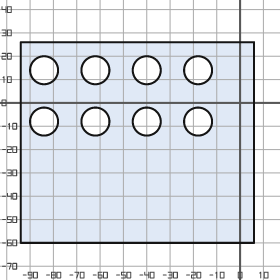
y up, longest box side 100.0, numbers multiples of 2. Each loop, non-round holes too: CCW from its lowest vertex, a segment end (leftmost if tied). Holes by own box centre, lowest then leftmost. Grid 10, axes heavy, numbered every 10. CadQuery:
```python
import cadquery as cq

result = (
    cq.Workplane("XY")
    .moveTo(-94.0, -60.0)
    .lineTo(6.0, -60.0)
    .lineTo(6.0, 26.0)
    .lineTo(-94.0, 26.0)
    .close()
    .moveTo(-84.0, -8.0)
    .circle(6.0)
    .moveTo(-62.0, -8.0)
    .circle(6.0)
    .moveTo(-40.0, -8.0)
    .circle(6.0)
    .moveTo(-18.0, -8.0)
    .circle(6.0)
    .moveTo(-84.0, 14.0)
    .circle(6.0)
    .moveTo(-62.0, 14.0)
    .circle(6.0)
    .moveTo(-40.0, 14.0)
    .circle(6.0)
    .moveTo(-18.0, 14.0)
    .circle(6.0)
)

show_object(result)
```